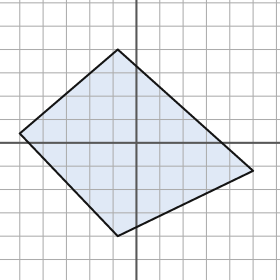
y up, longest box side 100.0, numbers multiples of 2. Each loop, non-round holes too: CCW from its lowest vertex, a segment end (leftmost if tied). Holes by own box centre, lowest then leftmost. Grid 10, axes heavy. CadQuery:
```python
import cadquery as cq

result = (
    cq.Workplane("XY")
    .moveTo(-8.0, -40.0)
    .lineTo(50.0, -12.0)
    .lineTo(-8.0, 40.0)
    .lineTo(-50.0, 4.0)
    .close()
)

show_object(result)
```